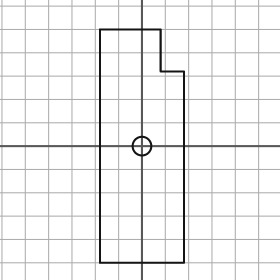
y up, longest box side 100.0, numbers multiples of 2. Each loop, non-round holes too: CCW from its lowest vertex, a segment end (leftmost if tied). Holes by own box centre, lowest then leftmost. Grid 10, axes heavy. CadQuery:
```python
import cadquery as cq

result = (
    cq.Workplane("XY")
    .moveTo(-18.0, -50.0)
    .lineTo(18.0, -50.0)
    .lineTo(18.0, 32.0)
    .lineTo(8.0, 32.0)
    .lineTo(8.0, 50.0)
    .lineTo(-18.0, 50.0)
    .close()
    .moveTo(0.0, 0.0)
    .circle(4.0)
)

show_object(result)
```